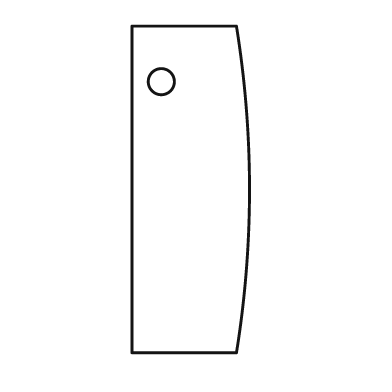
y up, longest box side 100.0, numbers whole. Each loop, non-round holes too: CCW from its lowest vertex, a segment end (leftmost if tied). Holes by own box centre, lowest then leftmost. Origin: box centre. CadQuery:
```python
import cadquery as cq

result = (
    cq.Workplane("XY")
    .moveTo(-18.0, -50.0)
    .lineTo(14.0, -50.0)
    .threePointArc((18.0, 0.0), (14.0, 50.0))
    .lineTo(-18.0, 50.0)
    .close()
    .moveTo(-9.0, 33.0)
    .circle(4.0)
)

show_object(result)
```